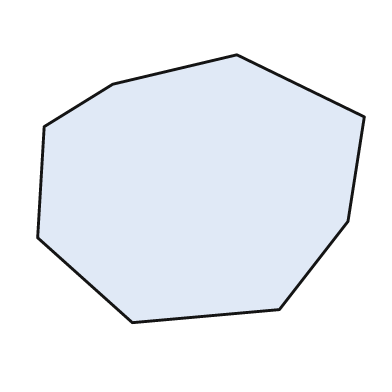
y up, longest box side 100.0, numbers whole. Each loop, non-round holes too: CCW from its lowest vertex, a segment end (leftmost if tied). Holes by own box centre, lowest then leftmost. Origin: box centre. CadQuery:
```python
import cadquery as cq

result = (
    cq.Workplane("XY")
    .moveTo(-21.0, -41.0)
    .lineTo(24.0, -37.0)
    .lineTo(45.0, -10.0)
    .lineTo(50.0, 22.0)
    .lineTo(11.0, 41.0)
    .lineTo(-27.0, 32.0)
    .lineTo(-48.0, 19.0)
    .lineTo(-50.0, -15.0)
    .close()
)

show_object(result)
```